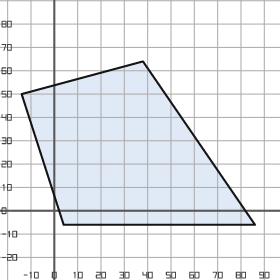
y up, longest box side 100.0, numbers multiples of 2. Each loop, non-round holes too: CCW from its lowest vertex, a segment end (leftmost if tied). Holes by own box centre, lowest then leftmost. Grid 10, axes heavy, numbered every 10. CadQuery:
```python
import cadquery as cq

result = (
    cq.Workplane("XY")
    .moveTo(4.0, -6.0)
    .lineTo(86.0, -6.0)
    .lineTo(38.0, 64.0)
    .lineTo(-14.0, 50.0)
    .close()
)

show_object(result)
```